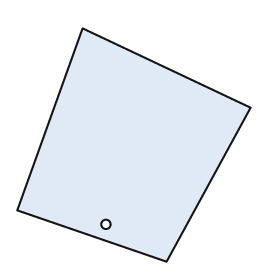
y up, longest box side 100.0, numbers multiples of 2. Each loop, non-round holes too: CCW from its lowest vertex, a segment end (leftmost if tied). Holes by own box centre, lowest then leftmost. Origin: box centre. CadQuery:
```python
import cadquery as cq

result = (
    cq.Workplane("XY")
    .moveTo(14.0, -50.0)
    .lineTo(50.0, 16.0)
    .lineTo(-22.0, 50.0)
    .lineTo(-50.0, -28.0)
    .close()
    .moveTo(-12.0, -34.0)
    .circle(2.0)
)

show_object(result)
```